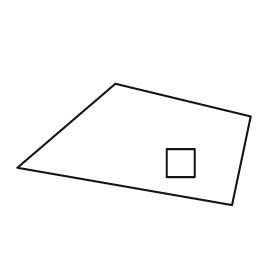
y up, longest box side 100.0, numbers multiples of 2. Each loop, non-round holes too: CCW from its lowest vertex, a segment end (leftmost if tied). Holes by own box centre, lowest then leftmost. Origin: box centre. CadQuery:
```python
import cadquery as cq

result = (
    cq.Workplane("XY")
    .moveTo(42.0, -26.0)
    .lineTo(50.0, 12.0)
    .lineTo(-8.0, 26.0)
    .lineTo(-50.0, -10.0)
    .close()
    .moveTo(14.0, -14.0)
    .lineTo(26.0, -14.0)
    .lineTo(26.0, -2.0)
    .lineTo(14.0, -2.0)
    .close()
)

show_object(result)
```